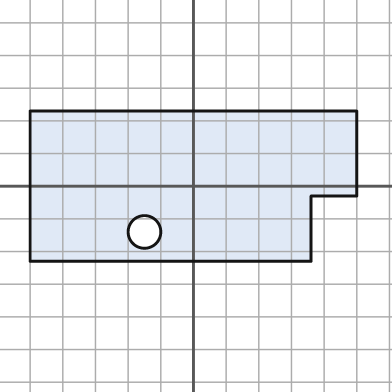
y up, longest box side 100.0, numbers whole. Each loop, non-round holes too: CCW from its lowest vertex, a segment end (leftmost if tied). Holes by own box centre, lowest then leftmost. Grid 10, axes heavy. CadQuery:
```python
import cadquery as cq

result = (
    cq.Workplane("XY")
    .moveTo(-50.0, -23.0)
    .lineTo(36.0, -23.0)
    .lineTo(36.0, -3.0)
    .lineTo(50.0, -3.0)
    .lineTo(50.0, 23.0)
    .lineTo(-50.0, 23.0)
    .close()
    .moveTo(-15.0, -14.0)
    .circle(5.0)
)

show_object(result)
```